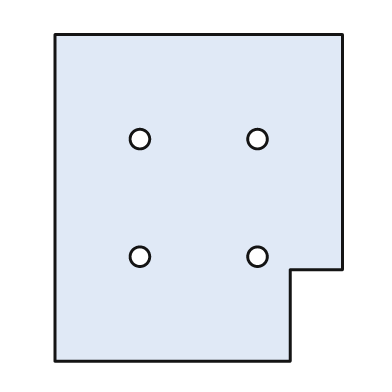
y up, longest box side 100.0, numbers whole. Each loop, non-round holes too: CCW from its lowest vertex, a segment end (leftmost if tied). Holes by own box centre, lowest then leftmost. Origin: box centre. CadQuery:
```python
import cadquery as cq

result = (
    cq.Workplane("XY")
    .moveTo(-44.0, -50.0)
    .lineTo(28.0, -50.0)
    .lineTo(28.0, -22.0)
    .lineTo(44.0, -22.0)
    .lineTo(44.0, 50.0)
    .lineTo(-44.0, 50.0)
    .close()
    .moveTo(-18.0, -18.0)
    .circle(3.0)
    .moveTo(18.0, -18.0)
    .circle(3.0)
    .moveTo(-18.0, 18.0)
    .circle(3.0)
    .moveTo(18.0, 18.0)
    .circle(3.0)
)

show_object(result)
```